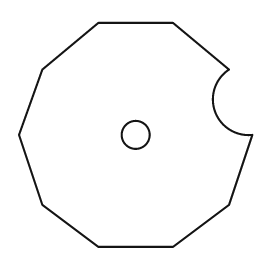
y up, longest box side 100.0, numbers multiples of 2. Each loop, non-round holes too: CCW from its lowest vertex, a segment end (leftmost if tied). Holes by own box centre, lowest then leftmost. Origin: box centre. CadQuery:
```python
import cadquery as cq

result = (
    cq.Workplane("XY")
    .moveTo(-16.0, -48.0)
    .lineTo(16.0, -48.0)
    .lineTo(40.0, -30.0)
    .lineTo(50.0, 0.0)
    .threePointArc((34.0, 10.0), (40.0, 28.0))
    .lineTo(16.0, 48.0)
    .lineTo(-16.0, 48.0)
    .lineTo(-40.0, 28.0)
    .lineTo(-50.0, 0.0)
    .lineTo(-40.0, -30.0)
    .close()
    .moveTo(0.0, 0.0)
    .circle(6.0)
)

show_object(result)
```